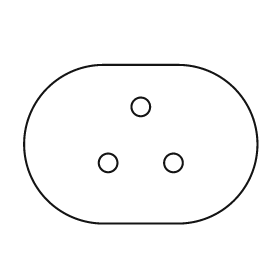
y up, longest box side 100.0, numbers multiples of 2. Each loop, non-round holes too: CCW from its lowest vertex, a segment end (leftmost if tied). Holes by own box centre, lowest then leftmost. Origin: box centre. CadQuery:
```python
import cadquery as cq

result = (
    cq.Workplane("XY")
    .moveTo(-16.0, -34.0)
    .lineTo(16.0, -34.0)
    .threePointArc((50.0, 0.0), (16.0, 34.0))
    .lineTo(-16.0, 34.0)
    .threePointArc((-50.0, 0.0), (-16.0, -34.0))
    .close()
    .moveTo(-14.0, -8.0)
    .circle(4.0)
    .moveTo(14.0, -8.0)
    .circle(4.0)
    .moveTo(0.0, 16.0)
    .circle(4.0)
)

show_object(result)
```